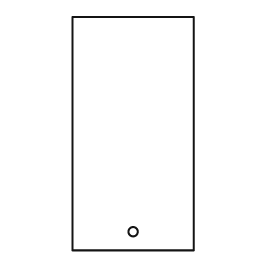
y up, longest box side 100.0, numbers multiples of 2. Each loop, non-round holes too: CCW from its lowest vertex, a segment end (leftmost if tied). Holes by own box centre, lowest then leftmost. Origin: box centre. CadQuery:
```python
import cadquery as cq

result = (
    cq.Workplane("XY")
    .moveTo(-26.0, -50.0)
    .lineTo(26.0, -50.0)
    .lineTo(26.0, 50.0)
    .lineTo(-26.0, 50.0)
    .close()
    .moveTo(0.0, -42.0)
    .circle(2.0)
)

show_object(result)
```